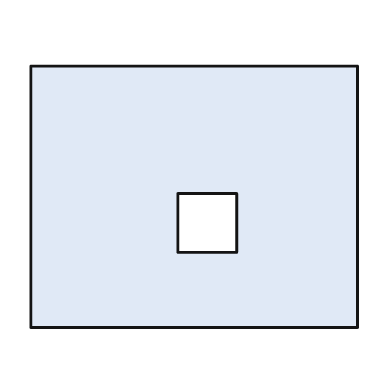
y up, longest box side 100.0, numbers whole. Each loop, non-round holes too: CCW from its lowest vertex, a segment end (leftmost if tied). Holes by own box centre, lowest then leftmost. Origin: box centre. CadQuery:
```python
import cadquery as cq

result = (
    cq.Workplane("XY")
    .moveTo(-50.0, -40.0)
    .lineTo(50.0, -40.0)
    .lineTo(50.0, 40.0)
    .lineTo(-50.0, 40.0)
    .close()
    .moveTo(-5.0, -17.0)
    .lineTo(13.0, -17.0)
    .lineTo(13.0, 1.0)
    .lineTo(-5.0, 1.0)
    .close()
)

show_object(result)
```